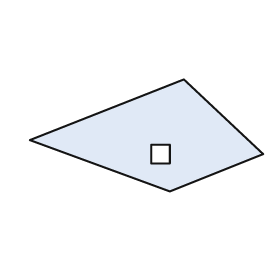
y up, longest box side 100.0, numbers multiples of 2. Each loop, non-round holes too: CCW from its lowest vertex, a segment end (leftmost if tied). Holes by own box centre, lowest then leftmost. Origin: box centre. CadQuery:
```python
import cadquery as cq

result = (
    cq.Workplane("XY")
    .moveTo(10.0, -24.0)
    .lineTo(50.0, -8.0)
    .lineTo(16.0, 24.0)
    .lineTo(-50.0, -2.0)
    .close()
    .moveTo(2.0, -12.0)
    .lineTo(10.0, -12.0)
    .lineTo(10.0, -4.0)
    .lineTo(2.0, -4.0)
    .close()
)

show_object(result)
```